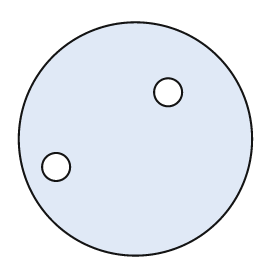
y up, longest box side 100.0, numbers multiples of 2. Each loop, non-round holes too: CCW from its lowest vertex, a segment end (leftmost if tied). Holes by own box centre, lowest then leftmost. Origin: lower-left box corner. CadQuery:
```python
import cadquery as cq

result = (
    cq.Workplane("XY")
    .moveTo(50.0, 50.0)
    .circle(50.0)
    .moveTo(16.0, 38.0)
    .circle(6.0)
    .moveTo(64.0, 70.0)
    .circle(6.0)
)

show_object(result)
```